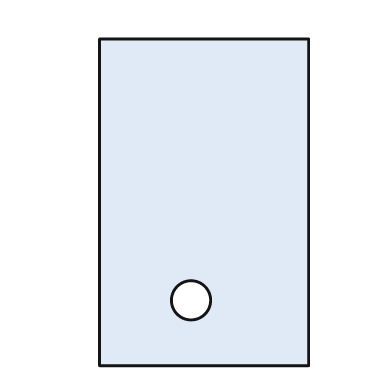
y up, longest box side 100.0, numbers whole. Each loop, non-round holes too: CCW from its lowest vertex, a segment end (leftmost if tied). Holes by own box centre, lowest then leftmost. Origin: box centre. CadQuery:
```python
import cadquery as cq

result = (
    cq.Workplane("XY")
    .moveTo(-32.0, -50.0)
    .lineTo(32.0, -50.0)
    .lineTo(32.0, 50.0)
    .lineTo(-32.0, 50.0)
    .close()
    .moveTo(-4.0, -30.0)
    .circle(6.0)
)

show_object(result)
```